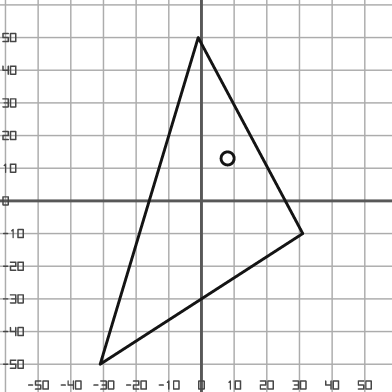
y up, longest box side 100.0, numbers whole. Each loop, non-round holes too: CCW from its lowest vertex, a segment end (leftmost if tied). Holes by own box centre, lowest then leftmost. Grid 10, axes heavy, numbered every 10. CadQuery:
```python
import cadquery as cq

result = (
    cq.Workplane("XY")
    .moveTo(-31.0, -50.0)
    .lineTo(31.0, -10.0)
    .lineTo(-1.0, 50.0)
    .close()
    .moveTo(8.0, 13.0)
    .circle(2.0)
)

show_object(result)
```